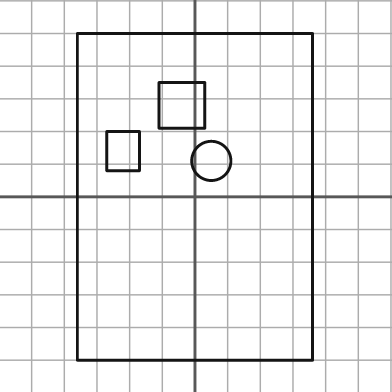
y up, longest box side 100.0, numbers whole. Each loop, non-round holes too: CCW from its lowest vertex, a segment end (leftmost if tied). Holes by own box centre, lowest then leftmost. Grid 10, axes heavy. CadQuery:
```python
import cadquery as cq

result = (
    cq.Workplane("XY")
    .moveTo(-36.0, -50.0)
    .lineTo(36.0, -50.0)
    .lineTo(36.0, 50.0)
    .lineTo(-36.0, 50.0)
    .close()
    .moveTo(5.0, 11.0)
    .circle(6.0)
    .moveTo(-27.0, 8.0)
    .lineTo(-17.0, 8.0)
    .lineTo(-17.0, 20.0)
    .lineTo(-27.0, 20.0)
    .close()
    .moveTo(-11.0, 21.0)
    .lineTo(3.0, 21.0)
    .lineTo(3.0, 35.0)
    .lineTo(-11.0, 35.0)
    .close()
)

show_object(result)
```